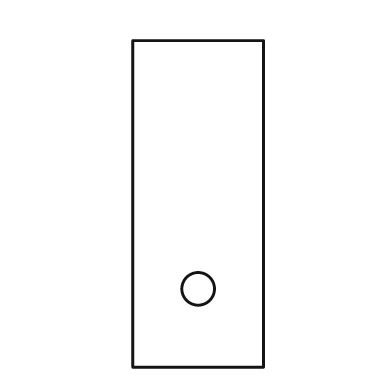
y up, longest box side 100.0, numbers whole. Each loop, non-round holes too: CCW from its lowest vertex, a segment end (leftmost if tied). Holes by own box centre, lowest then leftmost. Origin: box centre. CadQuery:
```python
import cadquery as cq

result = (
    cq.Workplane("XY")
    .moveTo(-20.0, -50.0)
    .lineTo(20.0, -50.0)
    .lineTo(20.0, 50.0)
    .lineTo(-20.0, 50.0)
    .close()
    .moveTo(0.0, -26.0)
    .circle(5.0)
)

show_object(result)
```